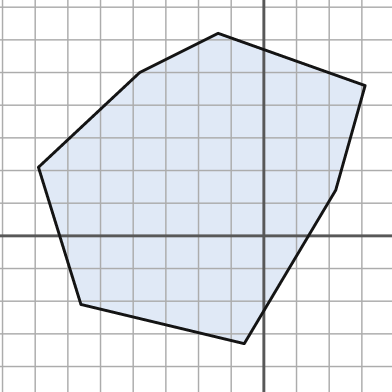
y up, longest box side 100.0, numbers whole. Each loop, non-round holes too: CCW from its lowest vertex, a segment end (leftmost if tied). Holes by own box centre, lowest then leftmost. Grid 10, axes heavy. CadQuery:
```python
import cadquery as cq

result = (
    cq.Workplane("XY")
    .moveTo(-6.0, -33.0)
    .lineTo(22.0, 14.0)
    .lineTo(31.0, 46.0)
    .lineTo(-14.0, 62.0)
    .lineTo(-38.0, 50.0)
    .lineTo(-69.0, 21.0)
    .lineTo(-56.0, -21.0)
    .close()
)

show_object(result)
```